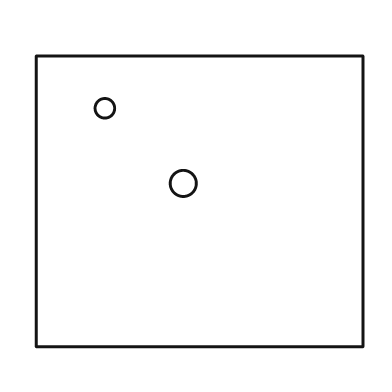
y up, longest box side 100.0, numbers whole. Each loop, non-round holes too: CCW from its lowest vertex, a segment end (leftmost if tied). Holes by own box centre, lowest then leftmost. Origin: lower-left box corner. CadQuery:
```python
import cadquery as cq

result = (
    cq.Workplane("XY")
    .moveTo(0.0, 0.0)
    .lineTo(100.0, 0.0)
    .lineTo(100.0, 89.0)
    .lineTo(0.0, 89.0)
    .close()
    .moveTo(45.0, 50.0)
    .circle(4.0)
    .moveTo(21.0, 73.0)
    .circle(3.0)
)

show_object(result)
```